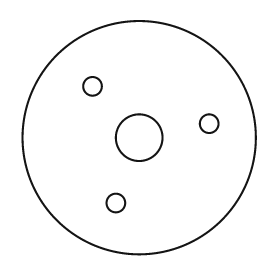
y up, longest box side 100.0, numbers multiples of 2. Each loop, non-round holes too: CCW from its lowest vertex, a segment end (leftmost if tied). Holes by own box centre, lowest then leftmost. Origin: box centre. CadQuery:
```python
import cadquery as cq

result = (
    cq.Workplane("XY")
    .moveTo(0.0, 0.0)
    .circle(50.0)
    .moveTo(-10.0, -28.0)
    .circle(4.0)
    .moveTo(0.0, 0.0)
    .circle(10.0)
    .moveTo(30.0, 6.0)
    .circle(4.0)
    .moveTo(-20.0, 22.0)
    .circle(4.0)
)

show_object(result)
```